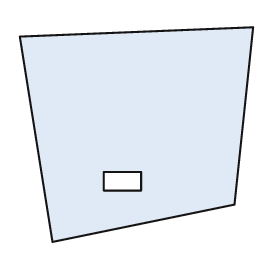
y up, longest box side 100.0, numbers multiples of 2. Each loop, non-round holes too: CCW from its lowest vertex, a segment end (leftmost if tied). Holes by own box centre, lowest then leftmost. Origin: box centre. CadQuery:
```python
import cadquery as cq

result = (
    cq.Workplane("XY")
    .moveTo(-36.0, -46.0)
    .lineTo(42.0, -30.0)
    .lineTo(50.0, 46.0)
    .lineTo(-50.0, 42.0)
    .close()
    .moveTo(-14.0, -24.0)
    .lineTo(2.0, -24.0)
    .lineTo(2.0, -16.0)
    .lineTo(-14.0, -16.0)
    .close()
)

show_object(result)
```